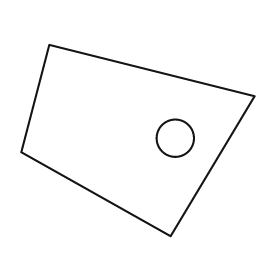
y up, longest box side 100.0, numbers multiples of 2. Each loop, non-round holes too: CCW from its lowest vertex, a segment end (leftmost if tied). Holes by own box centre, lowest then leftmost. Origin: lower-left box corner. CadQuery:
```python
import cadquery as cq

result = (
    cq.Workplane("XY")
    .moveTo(64.0, 0.0)
    .lineTo(100.0, 60.0)
    .lineTo(12.0, 82.0)
    .lineTo(0.0, 36.0)
    .close()
    .moveTo(66.0, 42.0)
    .circle(8.0)
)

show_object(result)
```